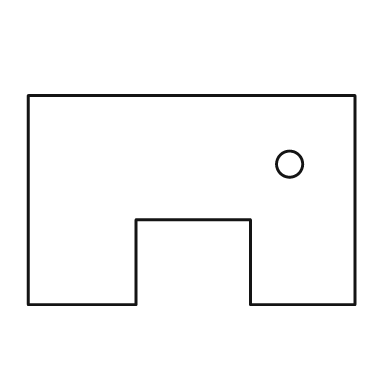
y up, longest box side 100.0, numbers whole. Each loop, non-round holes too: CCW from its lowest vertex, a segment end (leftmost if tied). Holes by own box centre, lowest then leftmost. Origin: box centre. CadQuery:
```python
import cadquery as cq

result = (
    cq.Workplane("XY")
    .moveTo(-50.0, -32.0)
    .lineTo(-17.0, -32.0)
    .lineTo(-17.0, -6.0)
    .lineTo(18.0, -6.0)
    .lineTo(18.0, -32.0)
    .lineTo(50.0, -32.0)
    .lineTo(50.0, 32.0)
    .lineTo(-50.0, 32.0)
    .close()
    .moveTo(30.0, 11.0)
    .circle(4.0)
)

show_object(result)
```